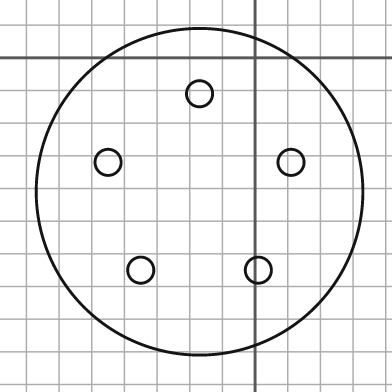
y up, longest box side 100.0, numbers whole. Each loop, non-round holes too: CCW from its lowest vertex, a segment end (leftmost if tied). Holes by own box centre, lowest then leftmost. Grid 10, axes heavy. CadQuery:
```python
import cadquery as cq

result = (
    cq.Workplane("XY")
    .moveTo(-17.0, -41.0)
    .circle(50.0)
    .moveTo(-35.0, -65.0)
    .circle(4.0)
    .moveTo(1.0, -65.0)
    .circle(4.0)
    .moveTo(-45.0, -32.0)
    .circle(4.0)
    .moveTo(11.0, -32.0)
    .circle(4.0)
    .moveTo(-17.0, -11.0)
    .circle(4.0)
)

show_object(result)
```